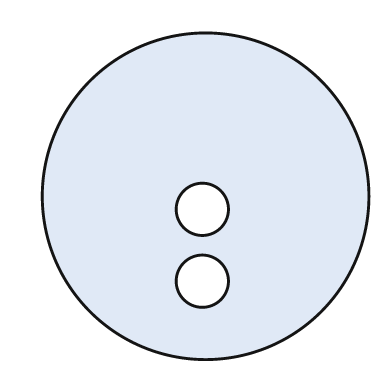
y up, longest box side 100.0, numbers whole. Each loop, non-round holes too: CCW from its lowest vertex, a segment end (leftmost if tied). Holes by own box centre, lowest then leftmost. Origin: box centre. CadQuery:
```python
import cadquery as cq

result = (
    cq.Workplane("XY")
    .moveTo(0.0, 0.0)
    .circle(50.0)
    .moveTo(-1.0, -26.0)
    .circle(8.0)
    .moveTo(-1.0, -4.0)
    .circle(8.0)
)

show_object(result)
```